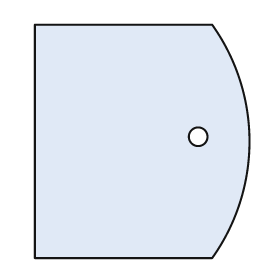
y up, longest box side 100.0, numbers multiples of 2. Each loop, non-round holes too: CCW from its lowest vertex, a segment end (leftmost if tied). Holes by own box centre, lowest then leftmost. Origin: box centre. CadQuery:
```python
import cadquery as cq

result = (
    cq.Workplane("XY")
    .moveTo(-46.0, -50.0)
    .lineTo(30.0, -50.0)
    .threePointArc((46.0, 0.0), (30.0, 50.0))
    .lineTo(-46.0, 50.0)
    .close()
    .moveTo(24.0, 2.0)
    .circle(4.0)
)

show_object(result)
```